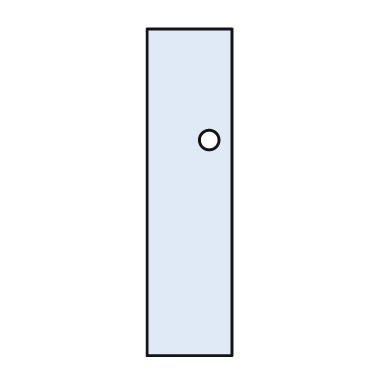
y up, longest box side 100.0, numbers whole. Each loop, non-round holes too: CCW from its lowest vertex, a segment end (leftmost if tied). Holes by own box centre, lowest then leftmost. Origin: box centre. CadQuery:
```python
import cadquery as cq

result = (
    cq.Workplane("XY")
    .moveTo(-13.0, -50.0)
    .lineTo(13.0, -50.0)
    .lineTo(13.0, 50.0)
    .lineTo(-13.0, 50.0)
    .close()
    .moveTo(6.0, 16.0)
    .circle(3.0)
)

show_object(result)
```